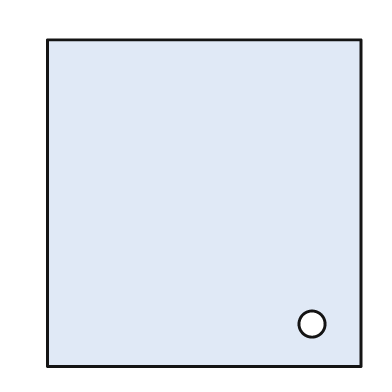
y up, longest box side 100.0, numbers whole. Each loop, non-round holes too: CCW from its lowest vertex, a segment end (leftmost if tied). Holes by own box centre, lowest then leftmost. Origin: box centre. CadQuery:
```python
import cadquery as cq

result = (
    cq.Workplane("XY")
    .moveTo(-48.0, -50.0)
    .lineTo(48.0, -50.0)
    .lineTo(48.0, 50.0)
    .lineTo(-48.0, 50.0)
    .close()
    .moveTo(33.0, -37.0)
    .circle(4.0)
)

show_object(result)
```